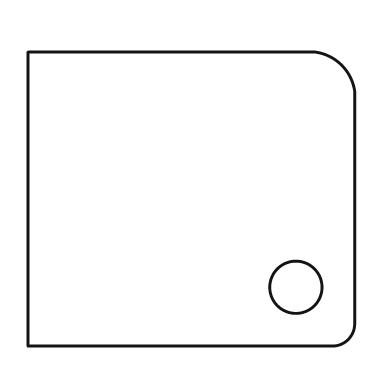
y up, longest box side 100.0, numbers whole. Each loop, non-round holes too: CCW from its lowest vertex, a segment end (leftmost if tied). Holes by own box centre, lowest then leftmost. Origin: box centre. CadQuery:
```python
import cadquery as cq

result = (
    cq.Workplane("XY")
    .moveTo(-50.0, -45.0)
    .lineTo(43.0, -45.0)
    .threePointArc((48.0, -43.0), (50.0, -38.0))
    .lineTo(50.0, 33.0)
    .threePointArc((46.0, 41.0), (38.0, 45.0))
    .lineTo(-50.0, 45.0)
    .close()
    .moveTo(32.0, -27.0)
    .circle(8.0)
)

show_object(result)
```